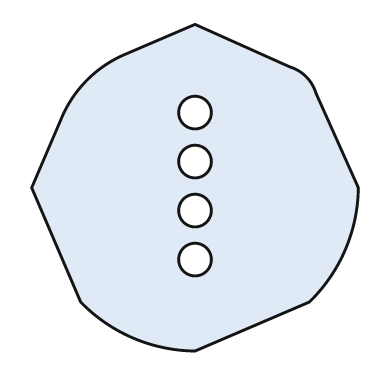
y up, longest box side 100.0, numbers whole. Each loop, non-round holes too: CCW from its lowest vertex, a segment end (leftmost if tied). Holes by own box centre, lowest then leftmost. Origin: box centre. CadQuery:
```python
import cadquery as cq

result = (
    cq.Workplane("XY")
    .moveTo(0.0, -50.0)
    .lineTo(35.0, -35.0)
    .threePointArc((46.0, -19.0), (50.0, 0.0))
    .lineTo(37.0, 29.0)
    .threePointArc((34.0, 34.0), (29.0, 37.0))
    .lineTo(0.0, 50.0)
    .lineTo(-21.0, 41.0)
    .threePointArc((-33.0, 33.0), (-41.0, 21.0))
    .lineTo(-50.0, 0.0)
    .lineTo(-35.0, -35.0)
    .threePointArc((-19.0, -46.0), (0.0, -50.0))
    .close()
    .moveTo(0.0, -22.0)
    .circle(5.0)
    .moveTo(0.0, -7.0)
    .circle(5.0)
    .moveTo(0.0, 8.0)
    .circle(5.0)
    .moveTo(0.0, 23.0)
    .circle(5.0)
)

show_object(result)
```